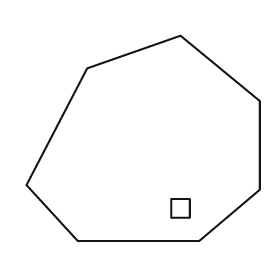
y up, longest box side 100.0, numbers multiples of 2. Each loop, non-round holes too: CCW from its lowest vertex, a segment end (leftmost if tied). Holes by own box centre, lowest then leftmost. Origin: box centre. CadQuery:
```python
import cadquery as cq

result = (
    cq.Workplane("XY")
    .moveTo(-28.0, -44.0)
    .lineTo(24.0, -44.0)
    .lineTo(50.0, -22.0)
    .lineTo(50.0, 16.0)
    .lineTo(16.0, 44.0)
    .lineTo(-24.0, 30.0)
    .lineTo(-50.0, -20.0)
    .close()
    .moveTo(12.0, -34.0)
    .lineTo(20.0, -34.0)
    .lineTo(20.0, -26.0)
    .lineTo(12.0, -26.0)
    .close()
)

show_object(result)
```